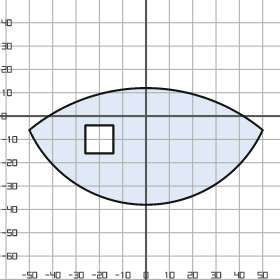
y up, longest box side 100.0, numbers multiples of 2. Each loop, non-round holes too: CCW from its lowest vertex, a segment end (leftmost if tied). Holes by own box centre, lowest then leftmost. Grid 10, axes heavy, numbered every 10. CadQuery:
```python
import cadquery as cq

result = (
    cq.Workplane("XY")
    .moveTo(-50.0, -6.0)
    .threePointArc((0.0, -38.0), (50.0, -6.0))
    .threePointArc((0.0, 12.0), (-50.0, -6.0))
    .close()
    .moveTo(-26.0, -16.0)
    .lineTo(-14.0, -16.0)
    .lineTo(-14.0, -4.0)
    .lineTo(-26.0, -4.0)
    .close()
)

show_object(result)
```